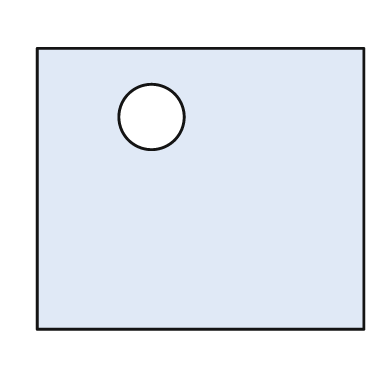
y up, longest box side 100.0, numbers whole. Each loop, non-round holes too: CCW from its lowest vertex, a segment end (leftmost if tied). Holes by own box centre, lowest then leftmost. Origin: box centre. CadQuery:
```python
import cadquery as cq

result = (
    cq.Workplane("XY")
    .moveTo(-50.0, -43.0)
    .lineTo(50.0, -43.0)
    .lineTo(50.0, 43.0)
    .lineTo(-50.0, 43.0)
    .close()
    .moveTo(-15.0, 22.0)
    .circle(10.0)
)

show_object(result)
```